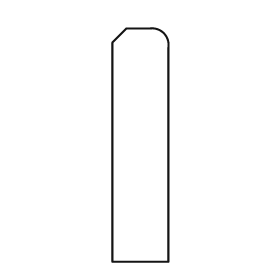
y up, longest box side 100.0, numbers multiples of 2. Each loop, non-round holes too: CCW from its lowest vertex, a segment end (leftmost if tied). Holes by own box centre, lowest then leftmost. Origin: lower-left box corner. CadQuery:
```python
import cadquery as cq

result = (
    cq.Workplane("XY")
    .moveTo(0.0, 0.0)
    .lineTo(24.0, 0.0)
    .lineTo(24.0, 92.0)
    .threePointArc((22.0, 98.0), (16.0, 100.0))
    .lineTo(6.0, 100.0)
    .lineTo(0.0, 94.0)
    .close()
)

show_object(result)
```